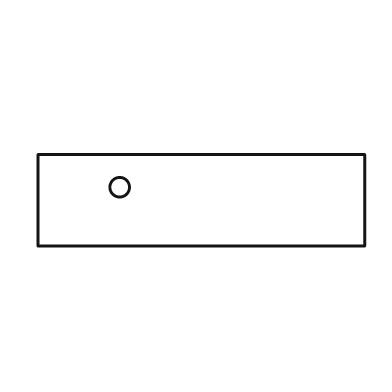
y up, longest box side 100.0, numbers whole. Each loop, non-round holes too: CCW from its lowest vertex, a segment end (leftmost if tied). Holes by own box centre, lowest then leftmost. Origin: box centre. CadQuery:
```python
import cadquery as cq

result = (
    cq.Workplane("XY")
    .moveTo(-50.0, -14.0)
    .lineTo(50.0, -14.0)
    .lineTo(50.0, 14.0)
    .lineTo(-50.0, 14.0)
    .close()
    .moveTo(-25.0, 4.0)
    .circle(3.0)
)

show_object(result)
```